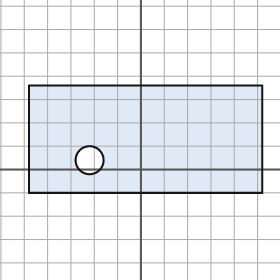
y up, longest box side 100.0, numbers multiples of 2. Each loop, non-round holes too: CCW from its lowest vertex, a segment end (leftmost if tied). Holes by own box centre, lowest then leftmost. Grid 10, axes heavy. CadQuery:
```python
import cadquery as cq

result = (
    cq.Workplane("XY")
    .moveTo(-48.0, -10.0)
    .lineTo(52.0, -10.0)
    .lineTo(52.0, 36.0)
    .lineTo(-48.0, 36.0)
    .close()
    .moveTo(-22.0, 4.0)
    .circle(6.0)
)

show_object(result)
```